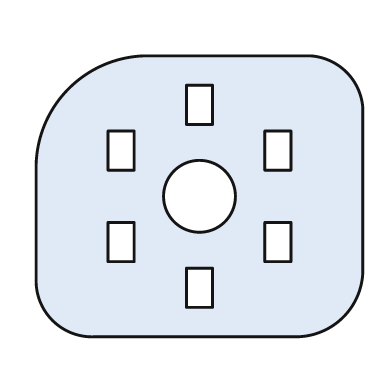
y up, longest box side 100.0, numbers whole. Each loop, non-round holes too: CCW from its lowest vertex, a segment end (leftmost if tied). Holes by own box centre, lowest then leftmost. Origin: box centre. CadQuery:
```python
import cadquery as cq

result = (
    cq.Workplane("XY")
    .moveTo(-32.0, -43.0)
    .lineTo(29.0, -43.0)
    .threePointArc((44.0, -37.0), (50.0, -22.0))
    .lineTo(50.0, 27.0)
    .threePointArc((45.0, 38.0), (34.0, 43.0))
    .lineTo(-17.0, 43.0)
    .threePointArc((-40.0, 33.0), (-50.0, 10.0))
    .lineTo(-50.0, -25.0)
    .threePointArc((-45.0, -38.0), (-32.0, -43.0))
    .close()
    .moveTo(-4.0, -34.0)
    .lineTo(4.0, -34.0)
    .lineTo(4.0, -22.0)
    .lineTo(-4.0, -22.0)
    .close()
    .moveTo(-28.0, -20.0)
    .lineTo(-20.0, -20.0)
    .lineTo(-20.0, -8.0)
    .lineTo(-28.0, -8.0)
    .close()
    .moveTo(20.0, -20.0)
    .lineTo(28.0, -20.0)
    .lineTo(28.0, -8.0)
    .lineTo(20.0, -8.0)
    .close()
    .moveTo(0.0, 0.0)
    .circle(11.0)
    .moveTo(-28.0, 8.0)
    .lineTo(-20.0, 8.0)
    .lineTo(-20.0, 20.0)
    .lineTo(-28.0, 20.0)
    .close()
    .moveTo(20.0, 8.0)
    .lineTo(28.0, 8.0)
    .lineTo(28.0, 20.0)
    .lineTo(20.0, 20.0)
    .close()
    .moveTo(-4.0, 22.0)
    .lineTo(4.0, 22.0)
    .lineTo(4.0, 34.0)
    .lineTo(-4.0, 34.0)
    .close()
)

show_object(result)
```